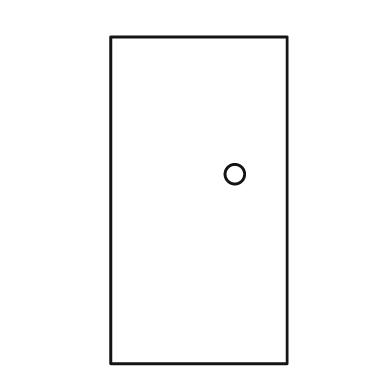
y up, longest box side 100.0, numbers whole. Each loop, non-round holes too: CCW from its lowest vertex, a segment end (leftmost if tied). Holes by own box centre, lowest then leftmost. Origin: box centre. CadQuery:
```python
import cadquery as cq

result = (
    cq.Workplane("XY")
    .moveTo(-27.0, -50.0)
    .lineTo(27.0, -50.0)
    .lineTo(27.0, 50.0)
    .lineTo(-27.0, 50.0)
    .close()
    .moveTo(11.0, 8.0)
    .circle(3.0)
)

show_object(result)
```